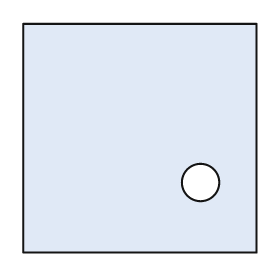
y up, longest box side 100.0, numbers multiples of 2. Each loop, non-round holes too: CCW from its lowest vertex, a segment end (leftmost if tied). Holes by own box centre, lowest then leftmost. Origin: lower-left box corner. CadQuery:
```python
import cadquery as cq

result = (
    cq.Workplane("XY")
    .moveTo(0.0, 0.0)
    .lineTo(100.0, 0.0)
    .lineTo(100.0, 98.0)
    .lineTo(0.0, 98.0)
    .close()
    .moveTo(76.0, 30.0)
    .circle(8.0)
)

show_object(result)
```